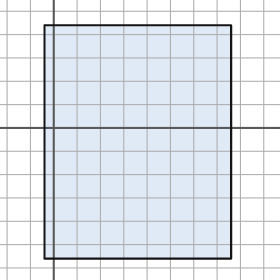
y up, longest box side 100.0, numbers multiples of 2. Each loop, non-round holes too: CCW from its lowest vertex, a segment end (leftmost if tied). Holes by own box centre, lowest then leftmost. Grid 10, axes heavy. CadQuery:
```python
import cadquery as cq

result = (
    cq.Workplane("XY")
    .moveTo(-4.0, -56.0)
    .lineTo(76.0, -56.0)
    .lineTo(76.0, 44.0)
    .lineTo(-4.0, 44.0)
    .close()
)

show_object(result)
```